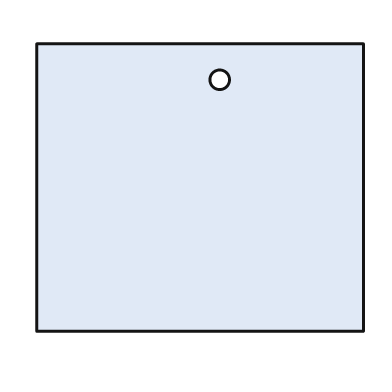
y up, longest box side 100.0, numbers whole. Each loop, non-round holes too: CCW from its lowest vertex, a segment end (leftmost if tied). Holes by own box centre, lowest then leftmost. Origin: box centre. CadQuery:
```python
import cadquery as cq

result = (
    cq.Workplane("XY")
    .moveTo(-50.0, -44.0)
    .lineTo(50.0, -44.0)
    .lineTo(50.0, 44.0)
    .lineTo(-50.0, 44.0)
    .close()
    .moveTo(6.0, 33.0)
    .circle(3.0)
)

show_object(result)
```